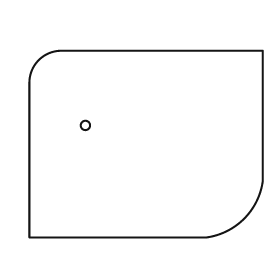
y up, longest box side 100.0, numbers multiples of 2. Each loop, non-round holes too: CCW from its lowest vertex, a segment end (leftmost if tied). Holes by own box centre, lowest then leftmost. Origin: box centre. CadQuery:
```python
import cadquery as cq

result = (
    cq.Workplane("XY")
    .moveTo(-50.0, -40.0)
    .lineTo(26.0, -40.0)
    .threePointArc((42.0, -32.0), (50.0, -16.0))
    .lineTo(50.0, 40.0)
    .lineTo(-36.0, 40.0)
    .threePointArc((-46.0, 36.0), (-50.0, 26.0))
    .close()
    .moveTo(-26.0, 8.0)
    .circle(2.0)
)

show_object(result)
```